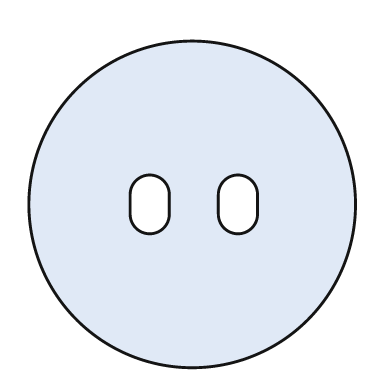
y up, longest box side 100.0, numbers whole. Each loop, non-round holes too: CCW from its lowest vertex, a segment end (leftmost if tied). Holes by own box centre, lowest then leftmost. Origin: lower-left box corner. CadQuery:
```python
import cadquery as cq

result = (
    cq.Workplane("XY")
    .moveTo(50.0, 50.0)
    .circle(50.0)
    .moveTo(31.0, 47.0)
    .threePointArc((37.0, 41.0), (43.0, 47.0))
    .lineTo(43.0, 53.0)
    .threePointArc((37.0, 59.0), (31.0, 53.0))
    .close()
    .moveTo(58.0, 47.0)
    .threePointArc((64.0, 41.0), (70.0, 47.0))
    .lineTo(70.0, 53.0)
    .threePointArc((64.0, 59.0), (58.0, 53.0))
    .close()
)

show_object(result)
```